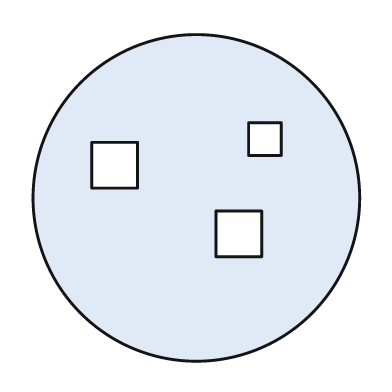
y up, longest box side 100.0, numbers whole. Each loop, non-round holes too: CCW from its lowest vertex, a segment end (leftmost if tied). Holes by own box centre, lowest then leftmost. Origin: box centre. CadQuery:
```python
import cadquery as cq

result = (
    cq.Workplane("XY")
    .moveTo(0.0, 0.0)
    .circle(50.0)
    .moveTo(6.0, -18.0)
    .lineTo(20.0, -18.0)
    .lineTo(20.0, -4.0)
    .lineTo(6.0, -4.0)
    .close()
    .moveTo(-32.0, 3.0)
    .lineTo(-18.0, 3.0)
    .lineTo(-18.0, 17.0)
    .lineTo(-32.0, 17.0)
    .close()
    .moveTo(16.0, 13.0)
    .lineTo(26.0, 13.0)
    .lineTo(26.0, 23.0)
    .lineTo(16.0, 23.0)
    .close()
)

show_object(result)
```